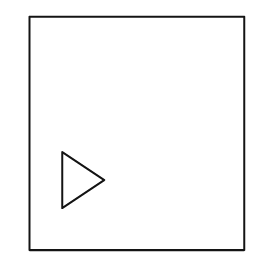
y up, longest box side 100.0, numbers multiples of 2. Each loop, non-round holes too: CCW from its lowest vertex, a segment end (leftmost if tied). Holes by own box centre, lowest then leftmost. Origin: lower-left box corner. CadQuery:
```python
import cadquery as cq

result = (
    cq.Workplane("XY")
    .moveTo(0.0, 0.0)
    .lineTo(92.0, 0.0)
    .lineTo(92.0, 100.0)
    .lineTo(0.0, 100.0)
    .close()
    .moveTo(14.0, 18.0)
    .lineTo(32.0, 30.0)
    .lineTo(14.0, 42.0)
    .close()
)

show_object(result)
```